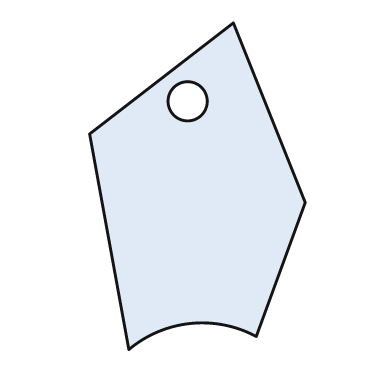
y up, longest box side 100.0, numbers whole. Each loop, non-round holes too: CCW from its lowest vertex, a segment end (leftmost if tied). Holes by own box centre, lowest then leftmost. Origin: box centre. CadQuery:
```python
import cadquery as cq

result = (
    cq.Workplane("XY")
    .moveTo(-21.0, -50.0)
    .threePointArc((-2.0, -42.0), (18.0, -46.0))
    .lineTo(33.0, -5.0)
    .lineTo(11.0, 50.0)
    .lineTo(-33.0, 16.0)
    .close()
    .moveTo(-3.0, 26.0)
    .circle(6.0)
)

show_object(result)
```